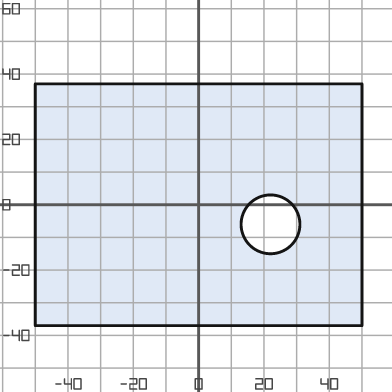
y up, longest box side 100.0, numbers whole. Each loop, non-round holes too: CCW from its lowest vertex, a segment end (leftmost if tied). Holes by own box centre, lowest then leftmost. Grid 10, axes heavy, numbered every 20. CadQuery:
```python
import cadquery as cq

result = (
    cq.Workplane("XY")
    .moveTo(-50.0, -37.0)
    .lineTo(50.0, -37.0)
    .lineTo(50.0, 37.0)
    .lineTo(-50.0, 37.0)
    .close()
    .moveTo(22.0, -6.0)
    .circle(9.0)
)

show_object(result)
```